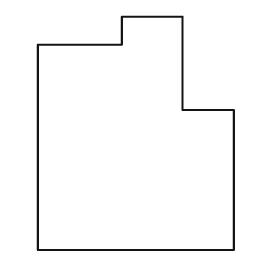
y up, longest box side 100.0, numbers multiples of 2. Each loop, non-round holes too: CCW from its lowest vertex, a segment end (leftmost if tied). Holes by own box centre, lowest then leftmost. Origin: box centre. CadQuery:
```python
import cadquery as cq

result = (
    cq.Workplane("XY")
    .moveTo(-42.0, -50.0)
    .lineTo(42.0, -50.0)
    .lineTo(42.0, 10.0)
    .lineTo(20.0, 10.0)
    .lineTo(20.0, 50.0)
    .lineTo(-6.0, 50.0)
    .lineTo(-6.0, 38.0)
    .lineTo(-42.0, 38.0)
    .close()
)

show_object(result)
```